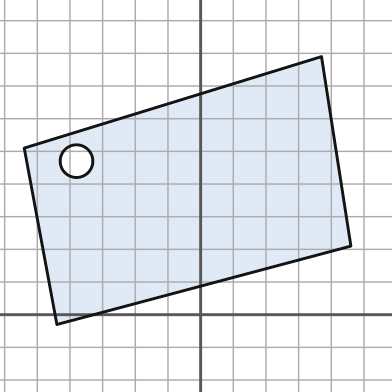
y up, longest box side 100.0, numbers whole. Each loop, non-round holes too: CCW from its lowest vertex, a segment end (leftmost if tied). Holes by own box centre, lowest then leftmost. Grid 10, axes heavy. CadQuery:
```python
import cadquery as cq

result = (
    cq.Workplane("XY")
    .moveTo(-44.0, -3.0)
    .lineTo(46.0, 21.0)
    .lineTo(37.0, 79.0)
    .lineTo(-54.0, 51.0)
    .close()
    .moveTo(-38.0, 47.0)
    .circle(5.0)
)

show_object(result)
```